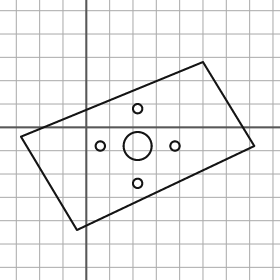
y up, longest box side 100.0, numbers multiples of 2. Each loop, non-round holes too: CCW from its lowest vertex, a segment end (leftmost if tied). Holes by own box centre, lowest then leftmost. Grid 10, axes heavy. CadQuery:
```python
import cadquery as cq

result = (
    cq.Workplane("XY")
    .moveTo(-4.0, -44.0)
    .lineTo(72.0, -8.0)
    .lineTo(50.0, 28.0)
    .lineTo(-28.0, -4.0)
    .close()
    .moveTo(22.0, -24.0)
    .circle(2.0)
    .moveTo(6.0, -8.0)
    .circle(2.0)
    .moveTo(22.0, -8.0)
    .circle(6.0)
    .moveTo(38.0, -8.0)
    .circle(2.0)
    .moveTo(22.0, 8.0)
    .circle(2.0)
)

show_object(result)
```